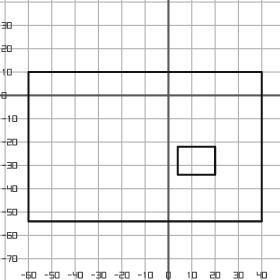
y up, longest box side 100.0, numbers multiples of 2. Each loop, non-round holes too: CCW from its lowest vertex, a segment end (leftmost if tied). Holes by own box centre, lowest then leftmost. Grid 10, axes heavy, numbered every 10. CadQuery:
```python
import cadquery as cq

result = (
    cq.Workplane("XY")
    .moveTo(-60.0, -54.0)
    .lineTo(40.0, -54.0)
    .lineTo(40.0, 10.0)
    .lineTo(-60.0, 10.0)
    .close()
    .moveTo(4.0, -34.0)
    .lineTo(20.0, -34.0)
    .lineTo(20.0, -22.0)
    .lineTo(4.0, -22.0)
    .close()
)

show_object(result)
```